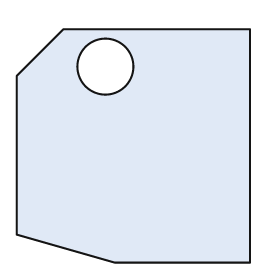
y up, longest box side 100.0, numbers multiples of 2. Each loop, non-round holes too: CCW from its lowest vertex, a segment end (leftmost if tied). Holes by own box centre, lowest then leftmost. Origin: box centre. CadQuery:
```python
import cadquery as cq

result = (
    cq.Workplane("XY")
    .moveTo(-8.0, -50.0)
    .lineTo(50.0, -50.0)
    .lineTo(50.0, 50.0)
    .lineTo(-30.0, 50.0)
    .lineTo(-50.0, 30.0)
    .lineTo(-50.0, -38.0)
    .close()
    .moveTo(-12.0, 34.0)
    .circle(12.0)
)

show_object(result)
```